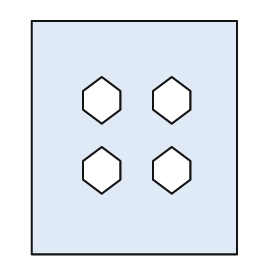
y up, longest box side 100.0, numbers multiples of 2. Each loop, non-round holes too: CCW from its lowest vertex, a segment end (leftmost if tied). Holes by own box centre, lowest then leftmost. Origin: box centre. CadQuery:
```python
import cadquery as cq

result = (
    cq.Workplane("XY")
    .moveTo(-44.0, -50.0)
    .lineTo(44.0, -50.0)
    .lineTo(44.0, 50.0)
    .lineTo(-44.0, 50.0)
    .close()
    .moveTo(-14.0, -24.0)
    .lineTo(-6.0, -18.0)
    .lineTo(-6.0, -10.0)
    .lineTo(-14.0, -4.0)
    .lineTo(-22.0, -10.0)
    .lineTo(-22.0, -18.0)
    .close()
    .moveTo(16.0, -24.0)
    .lineTo(24.0, -18.0)
    .lineTo(24.0, -10.0)
    .lineTo(16.0, -4.0)
    .lineTo(8.0, -10.0)
    .lineTo(8.0, -18.0)
    .close()
    .moveTo(-14.0, 6.0)
    .lineTo(-6.0, 12.0)
    .lineTo(-6.0, 20.0)
    .lineTo(-14.0, 26.0)
    .lineTo(-22.0, 20.0)
    .lineTo(-22.0, 12.0)
    .close()
    .moveTo(16.0, 6.0)
    .lineTo(24.0, 12.0)
    .lineTo(24.0, 20.0)
    .lineTo(16.0, 26.0)
    .lineTo(8.0, 20.0)
    .lineTo(8.0, 12.0)
    .close()
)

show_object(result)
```